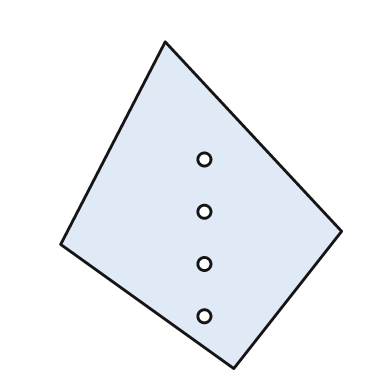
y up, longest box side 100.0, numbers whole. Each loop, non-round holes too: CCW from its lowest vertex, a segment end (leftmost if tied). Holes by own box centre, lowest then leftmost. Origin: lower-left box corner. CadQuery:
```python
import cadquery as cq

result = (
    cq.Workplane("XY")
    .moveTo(53.0, 0.0)
    .lineTo(86.0, 42.0)
    .lineTo(32.0, 100.0)
    .lineTo(0.0, 38.0)
    .close()
    .moveTo(44.0, 16.0)
    .circle(2.0)
    .moveTo(44.0, 32.0)
    .circle(2.0)
    .moveTo(44.0, 48.0)
    .circle(2.0)
    .moveTo(44.0, 64.0)
    .circle(2.0)
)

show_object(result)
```